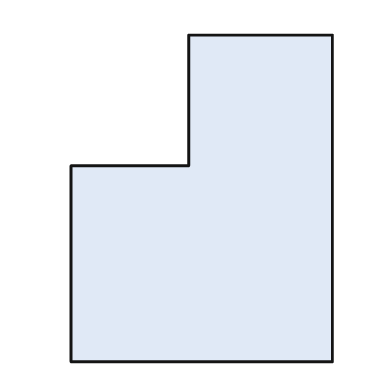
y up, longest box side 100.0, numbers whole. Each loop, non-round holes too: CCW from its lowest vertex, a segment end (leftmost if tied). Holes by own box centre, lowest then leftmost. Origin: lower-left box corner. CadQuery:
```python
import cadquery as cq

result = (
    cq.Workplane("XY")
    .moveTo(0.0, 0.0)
    .lineTo(80.0, 0.0)
    .lineTo(80.0, 100.0)
    .lineTo(36.0, 100.0)
    .lineTo(36.0, 60.0)
    .lineTo(0.0, 60.0)
    .close()
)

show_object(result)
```